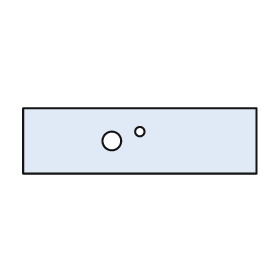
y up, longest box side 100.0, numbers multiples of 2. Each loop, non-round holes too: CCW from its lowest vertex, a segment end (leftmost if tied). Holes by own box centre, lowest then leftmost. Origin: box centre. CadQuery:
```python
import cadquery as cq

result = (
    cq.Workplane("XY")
    .moveTo(-50.0, -14.0)
    .lineTo(50.0, -14.0)
    .lineTo(50.0, 14.0)
    .lineTo(-50.0, 14.0)
    .close()
    .moveTo(-12.0, 0.0)
    .circle(4.0)
    .moveTo(0.0, 4.0)
    .circle(2.0)
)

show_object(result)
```